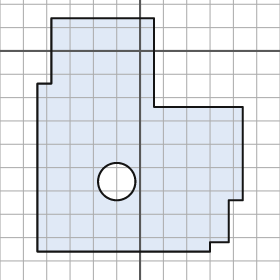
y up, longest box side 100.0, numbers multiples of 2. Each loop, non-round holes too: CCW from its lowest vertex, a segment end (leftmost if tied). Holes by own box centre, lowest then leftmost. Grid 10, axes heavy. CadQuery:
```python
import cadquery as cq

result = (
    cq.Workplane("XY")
    .moveTo(-44.0, -86.0)
    .lineTo(30.0, -86.0)
    .lineTo(30.0, -82.0)
    .lineTo(38.0, -82.0)
    .lineTo(38.0, -64.0)
    .lineTo(44.0, -64.0)
    .lineTo(44.0, -24.0)
    .lineTo(6.0, -24.0)
    .lineTo(6.0, 14.0)
    .lineTo(-38.0, 14.0)
    .lineTo(-38.0, -14.0)
    .lineTo(-44.0, -14.0)
    .close()
    .moveTo(-10.0, -56.0)
    .circle(8.0)
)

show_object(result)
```